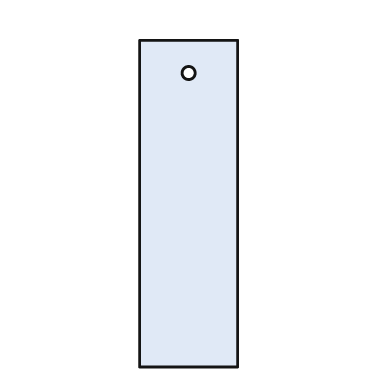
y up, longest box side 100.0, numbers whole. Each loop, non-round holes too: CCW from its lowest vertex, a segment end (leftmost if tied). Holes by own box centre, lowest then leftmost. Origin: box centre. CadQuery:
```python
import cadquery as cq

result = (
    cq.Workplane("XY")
    .moveTo(-15.0, -50.0)
    .lineTo(15.0, -50.0)
    .lineTo(15.0, 50.0)
    .lineTo(-15.0, 50.0)
    .close()
    .moveTo(0.0, 40.0)
    .circle(2.0)
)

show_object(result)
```